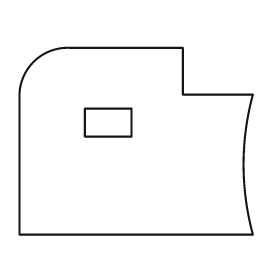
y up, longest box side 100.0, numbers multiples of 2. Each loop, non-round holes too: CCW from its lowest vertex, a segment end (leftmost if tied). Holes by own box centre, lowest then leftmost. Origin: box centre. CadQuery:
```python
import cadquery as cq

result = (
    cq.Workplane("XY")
    .moveTo(-50.0, -40.0)
    .lineTo(50.0, -40.0)
    .threePointArc((46.0, -10.0), (50.0, 20.0))
    .lineTo(20.0, 20.0)
    .lineTo(20.0, 40.0)
    .lineTo(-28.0, 40.0)
    .threePointArc((-44.0, 34.0), (-50.0, 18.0))
    .close()
    .moveTo(-22.0, 2.0)
    .lineTo(-2.0, 2.0)
    .lineTo(-2.0, 14.0)
    .lineTo(-22.0, 14.0)
    .close()
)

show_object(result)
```